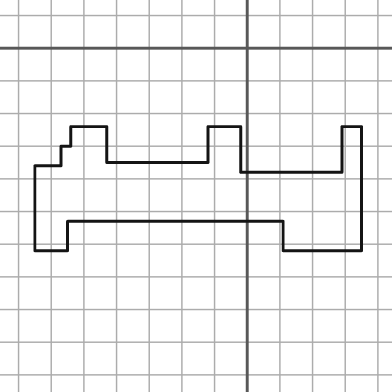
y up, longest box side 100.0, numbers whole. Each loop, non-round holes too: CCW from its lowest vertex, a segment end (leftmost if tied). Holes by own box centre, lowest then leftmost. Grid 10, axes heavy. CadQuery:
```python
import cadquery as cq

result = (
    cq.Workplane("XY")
    .moveTo(-65.0, -62.0)
    .lineTo(-55.0, -62.0)
    .lineTo(-55.0, -53.0)
    .lineTo(11.0, -53.0)
    .lineTo(11.0, -62.0)
    .lineTo(35.0, -62.0)
    .lineTo(35.0, -24.0)
    .lineTo(29.0, -24.0)
    .lineTo(29.0, -38.0)
    .lineTo(-2.0, -38.0)
    .lineTo(-2.0, -24.0)
    .lineTo(-12.0, -24.0)
    .lineTo(-12.0, -35.0)
    .lineTo(-43.0, -35.0)
    .lineTo(-43.0, -24.0)
    .lineTo(-54.0, -24.0)
    .lineTo(-54.0, -30.0)
    .lineTo(-57.0, -30.0)
    .lineTo(-57.0, -36.0)
    .lineTo(-65.0, -36.0)
    .close()
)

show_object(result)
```